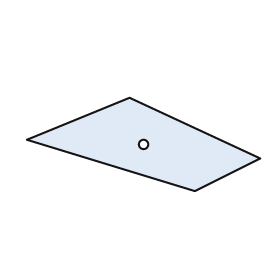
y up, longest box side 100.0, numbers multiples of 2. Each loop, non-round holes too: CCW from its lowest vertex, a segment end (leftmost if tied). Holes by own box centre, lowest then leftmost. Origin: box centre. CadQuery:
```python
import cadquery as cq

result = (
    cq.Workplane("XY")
    .moveTo(22.0, -20.0)
    .lineTo(50.0, -6.0)
    .lineTo(-6.0, 20.0)
    .lineTo(-50.0, 2.0)
    .close()
    .moveTo(0.0, 0.0)
    .circle(2.0)
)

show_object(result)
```